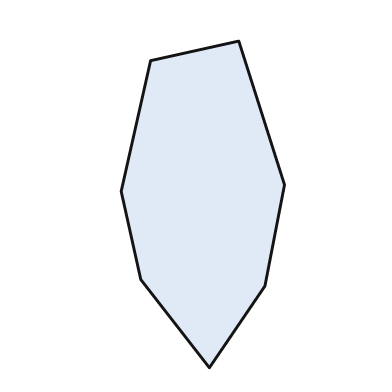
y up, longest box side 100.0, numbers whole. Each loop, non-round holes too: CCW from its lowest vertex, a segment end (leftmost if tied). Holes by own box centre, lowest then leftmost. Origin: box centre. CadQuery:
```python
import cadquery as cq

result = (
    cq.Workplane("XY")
    .moveTo(2.0, -50.0)
    .lineTo(19.0, -25.0)
    .lineTo(25.0, 6.0)
    .lineTo(11.0, 50.0)
    .lineTo(-16.0, 44.0)
    .lineTo(-25.0, 4.0)
    .lineTo(-19.0, -23.0)
    .close()
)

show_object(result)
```